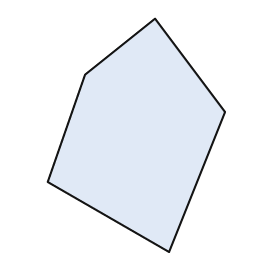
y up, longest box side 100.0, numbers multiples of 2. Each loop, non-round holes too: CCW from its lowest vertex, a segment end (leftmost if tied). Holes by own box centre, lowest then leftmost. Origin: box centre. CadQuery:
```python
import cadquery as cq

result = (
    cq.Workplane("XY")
    .moveTo(14.0, -50.0)
    .lineTo(38.0, 10.0)
    .lineTo(8.0, 50.0)
    .lineTo(-22.0, 26.0)
    .lineTo(-38.0, -20.0)
    .close()
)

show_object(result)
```